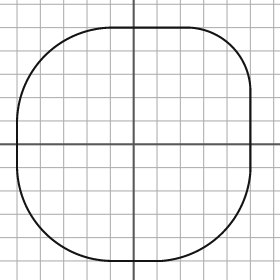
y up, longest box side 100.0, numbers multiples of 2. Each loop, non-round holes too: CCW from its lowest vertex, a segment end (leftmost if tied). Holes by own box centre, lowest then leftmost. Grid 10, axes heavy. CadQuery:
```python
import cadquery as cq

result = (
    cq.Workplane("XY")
    .moveTo(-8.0, -50.0)
    .lineTo(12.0, -50.0)
    .threePointArc((38.0, -38.0), (50.0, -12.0))
    .lineTo(50.0, 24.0)
    .threePointArc((42.0, 42.0), (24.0, 50.0))
    .lineTo(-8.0, 50.0)
    .threePointArc((-38.0, 38.0), (-50.0, 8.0))
    .lineTo(-50.0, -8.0)
    .threePointArc((-38.0, -38.0), (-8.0, -50.0))
    .close()
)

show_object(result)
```